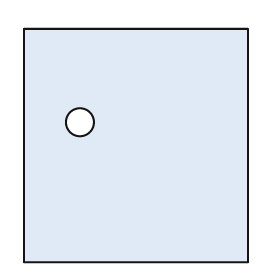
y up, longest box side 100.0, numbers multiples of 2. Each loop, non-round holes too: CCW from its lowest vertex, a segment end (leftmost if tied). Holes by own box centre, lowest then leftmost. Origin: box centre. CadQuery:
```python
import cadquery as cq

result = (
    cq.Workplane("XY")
    .moveTo(-48.0, -50.0)
    .lineTo(48.0, -50.0)
    .lineTo(48.0, 50.0)
    .lineTo(-48.0, 50.0)
    .close()
    .moveTo(-24.0, 10.0)
    .circle(6.0)
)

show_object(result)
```